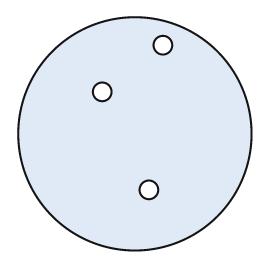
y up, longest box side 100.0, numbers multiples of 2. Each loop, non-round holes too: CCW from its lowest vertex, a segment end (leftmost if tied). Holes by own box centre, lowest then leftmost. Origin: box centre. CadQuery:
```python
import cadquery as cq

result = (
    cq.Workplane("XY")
    .moveTo(0.0, 0.0)
    .circle(50.0)
    .moveTo(6.0, -24.0)
    .circle(4.0)
    .moveTo(-14.0, 18.0)
    .circle(4.0)
    .moveTo(12.0, 38.0)
    .circle(4.0)
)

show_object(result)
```